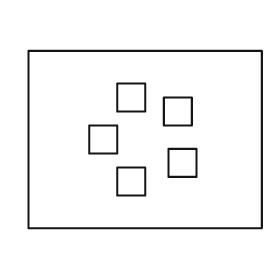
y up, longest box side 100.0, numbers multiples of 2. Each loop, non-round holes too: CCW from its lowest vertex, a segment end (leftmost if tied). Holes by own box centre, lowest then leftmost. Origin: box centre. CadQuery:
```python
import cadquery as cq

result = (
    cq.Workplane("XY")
    .moveTo(-50.0, -38.0)
    .lineTo(50.0, -38.0)
    .lineTo(50.0, 38.0)
    .lineTo(-50.0, 38.0)
    .close()
    .moveTo(-12.0, -24.0)
    .lineTo(0.0, -24.0)
    .lineTo(0.0, -12.0)
    .lineTo(-12.0, -12.0)
    .close()
    .moveTo(10.0, -16.0)
    .lineTo(22.0, -16.0)
    .lineTo(22.0, -4.0)
    .lineTo(10.0, -4.0)
    .close()
    .moveTo(-24.0, -6.0)
    .lineTo(-12.0, -6.0)
    .lineTo(-12.0, 6.0)
    .lineTo(-24.0, 6.0)
    .close()
    .moveTo(8.0, 6.0)
    .lineTo(20.0, 6.0)
    .lineTo(20.0, 18.0)
    .lineTo(8.0, 18.0)
    .close()
    .moveTo(-12.0, 12.0)
    .lineTo(0.0, 12.0)
    .lineTo(0.0, 24.0)
    .lineTo(-12.0, 24.0)
    .close()
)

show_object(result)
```